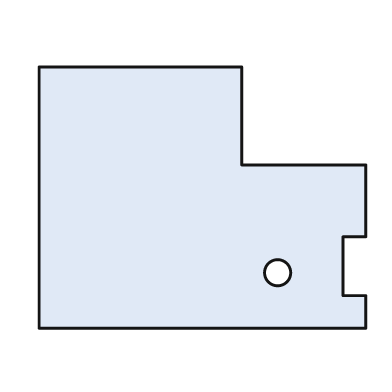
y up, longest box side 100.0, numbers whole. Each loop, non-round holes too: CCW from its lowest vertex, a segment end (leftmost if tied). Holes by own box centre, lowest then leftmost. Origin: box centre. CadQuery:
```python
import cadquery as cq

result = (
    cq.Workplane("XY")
    .moveTo(-50.0, -40.0)
    .lineTo(50.0, -40.0)
    .lineTo(50.0, -30.0)
    .lineTo(43.0, -30.0)
    .lineTo(43.0, -12.0)
    .lineTo(50.0, -12.0)
    .lineTo(50.0, 10.0)
    .lineTo(12.0, 10.0)
    .lineTo(12.0, 40.0)
    .lineTo(-50.0, 40.0)
    .close()
    .moveTo(23.0, -23.0)
    .circle(4.0)
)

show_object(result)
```